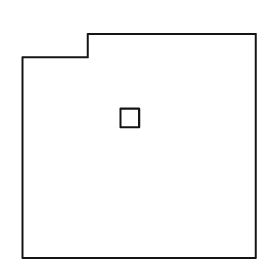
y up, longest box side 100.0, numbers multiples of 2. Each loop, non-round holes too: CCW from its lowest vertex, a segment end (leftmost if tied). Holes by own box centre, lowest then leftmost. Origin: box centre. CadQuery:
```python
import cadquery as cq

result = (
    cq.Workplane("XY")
    .moveTo(-50.0, -48.0)
    .lineTo(50.0, -48.0)
    .lineTo(50.0, 48.0)
    .lineTo(-22.0, 48.0)
    .lineTo(-22.0, 38.0)
    .lineTo(-50.0, 38.0)
    .close()
    .moveTo(-8.0, 8.0)
    .lineTo(0.0, 8.0)
    .lineTo(0.0, 16.0)
    .lineTo(-8.0, 16.0)
    .close()
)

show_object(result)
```